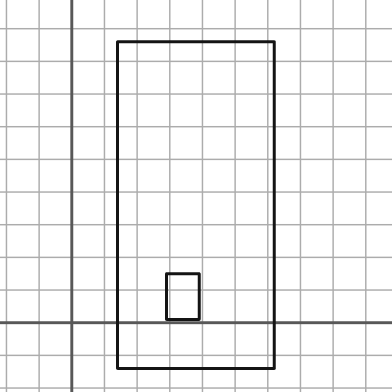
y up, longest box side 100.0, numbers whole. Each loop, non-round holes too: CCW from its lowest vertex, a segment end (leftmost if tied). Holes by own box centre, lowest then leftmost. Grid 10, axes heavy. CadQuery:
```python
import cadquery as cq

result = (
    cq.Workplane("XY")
    .moveTo(14.0, -14.0)
    .lineTo(62.0, -14.0)
    .lineTo(62.0, 86.0)
    .lineTo(14.0, 86.0)
    .close()
    .moveTo(29.0, 1.0)
    .lineTo(39.0, 1.0)
    .lineTo(39.0, 15.0)
    .lineTo(29.0, 15.0)
    .close()
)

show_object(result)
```